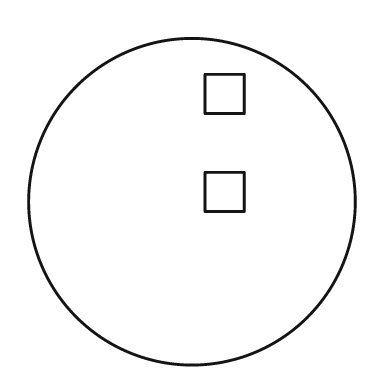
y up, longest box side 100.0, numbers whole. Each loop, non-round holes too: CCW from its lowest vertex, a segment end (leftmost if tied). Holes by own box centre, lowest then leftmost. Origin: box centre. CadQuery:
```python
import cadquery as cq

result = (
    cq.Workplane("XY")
    .moveTo(0.0, 0.0)
    .circle(50.0)
    .moveTo(4.0, -3.0)
    .lineTo(16.0, -3.0)
    .lineTo(16.0, 9.0)
    .lineTo(4.0, 9.0)
    .close()
    .moveTo(4.0, 27.0)
    .lineTo(16.0, 27.0)
    .lineTo(16.0, 39.0)
    .lineTo(4.0, 39.0)
    .close()
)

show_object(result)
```